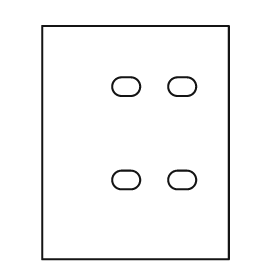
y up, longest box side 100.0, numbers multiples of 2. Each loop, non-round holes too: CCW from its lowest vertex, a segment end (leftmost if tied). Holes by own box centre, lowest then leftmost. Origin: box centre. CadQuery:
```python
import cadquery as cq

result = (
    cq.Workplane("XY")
    .moveTo(-40.0, -50.0)
    .lineTo(40.0, -50.0)
    .lineTo(40.0, 50.0)
    .lineTo(-40.0, 50.0)
    .close()
    .moveTo(-6.0, -20.0)
    .lineTo(-2.0, -20.0)
    .threePointArc((2.0, -16.0), (-2.0, -12.0))
    .lineTo(-6.0, -12.0)
    .threePointArc((-10.0, -16.0), (-6.0, -20.0))
    .close()
    .moveTo(18.0, -20.0)
    .lineTo(22.0, -20.0)
    .threePointArc((26.0, -16.0), (22.0, -12.0))
    .lineTo(18.0, -12.0)
    .threePointArc((14.0, -16.0), (18.0, -20.0))
    .close()
    .moveTo(-6.0, 20.0)
    .lineTo(-2.0, 20.0)
    .threePointArc((2.0, 24.0), (-2.0, 28.0))
    .lineTo(-6.0, 28.0)
    .threePointArc((-10.0, 24.0), (-6.0, 20.0))
    .close()
    .moveTo(18.0, 20.0)
    .lineTo(22.0, 20.0)
    .threePointArc((26.0, 24.0), (22.0, 28.0))
    .lineTo(18.0, 28.0)
    .threePointArc((14.0, 24.0), (18.0, 20.0))
    .close()
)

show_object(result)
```